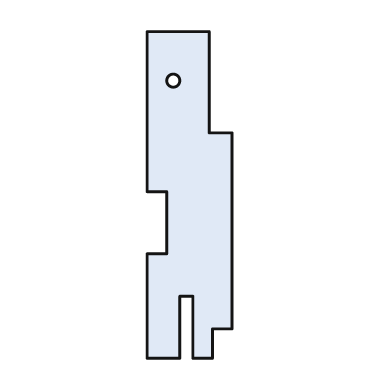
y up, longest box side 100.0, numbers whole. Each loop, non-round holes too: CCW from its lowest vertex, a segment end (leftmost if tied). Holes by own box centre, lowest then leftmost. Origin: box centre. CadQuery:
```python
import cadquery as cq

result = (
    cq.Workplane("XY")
    .moveTo(-13.0, -50.0)
    .lineTo(-3.0, -50.0)
    .lineTo(-3.0, -31.0)
    .lineTo(1.0, -31.0)
    .lineTo(1.0, -50.0)
    .lineTo(7.0, -50.0)
    .lineTo(7.0, -41.0)
    .lineTo(13.0, -41.0)
    .lineTo(13.0, 19.0)
    .lineTo(6.0, 19.0)
    .lineTo(6.0, 50.0)
    .lineTo(-13.0, 50.0)
    .lineTo(-13.0, 1.0)
    .lineTo(-7.0, 1.0)
    .lineTo(-7.0, -18.0)
    .lineTo(-13.0, -18.0)
    .close()
    .moveTo(-5.0, 35.0)
    .circle(2.0)
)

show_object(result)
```